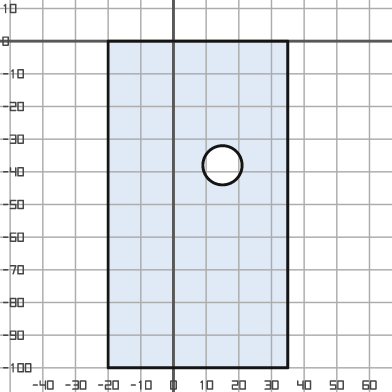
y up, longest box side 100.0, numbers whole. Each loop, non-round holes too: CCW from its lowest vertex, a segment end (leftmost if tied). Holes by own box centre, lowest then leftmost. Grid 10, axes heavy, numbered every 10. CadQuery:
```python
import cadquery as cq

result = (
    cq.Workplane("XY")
    .moveTo(-20.0, -100.0)
    .lineTo(35.0, -100.0)
    .lineTo(35.0, 0.0)
    .lineTo(-20.0, 0.0)
    .close()
    .moveTo(15.0, -38.0)
    .circle(6.0)
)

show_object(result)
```